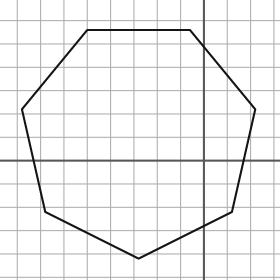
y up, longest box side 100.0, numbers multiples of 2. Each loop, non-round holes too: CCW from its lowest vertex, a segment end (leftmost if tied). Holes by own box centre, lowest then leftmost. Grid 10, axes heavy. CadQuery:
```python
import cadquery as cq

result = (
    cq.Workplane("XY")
    .moveTo(-28.0, -42.0)
    .lineTo(12.0, -22.0)
    .lineTo(22.0, 22.0)
    .lineTo(-6.0, 56.0)
    .lineTo(-50.0, 56.0)
    .lineTo(-78.0, 22.0)
    .lineTo(-68.0, -22.0)
    .close()
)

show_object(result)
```